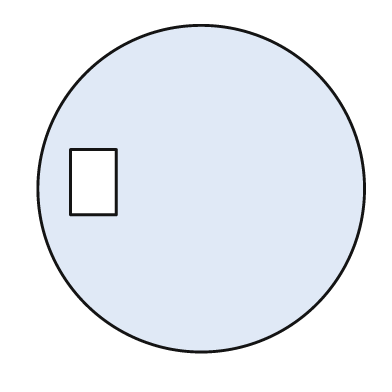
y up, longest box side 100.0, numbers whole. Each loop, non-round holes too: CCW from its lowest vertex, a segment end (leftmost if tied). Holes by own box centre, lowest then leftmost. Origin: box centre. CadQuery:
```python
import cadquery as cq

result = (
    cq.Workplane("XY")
    .moveTo(0.0, 0.0)
    .circle(50.0)
    .moveTo(-40.0, -8.0)
    .lineTo(-26.0, -8.0)
    .lineTo(-26.0, 12.0)
    .lineTo(-40.0, 12.0)
    .close()
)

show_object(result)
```